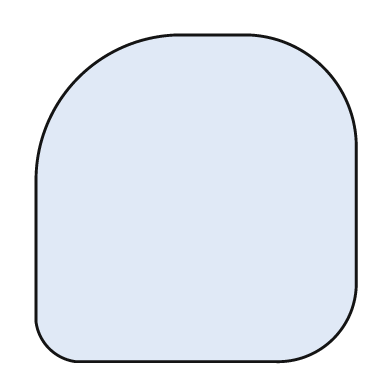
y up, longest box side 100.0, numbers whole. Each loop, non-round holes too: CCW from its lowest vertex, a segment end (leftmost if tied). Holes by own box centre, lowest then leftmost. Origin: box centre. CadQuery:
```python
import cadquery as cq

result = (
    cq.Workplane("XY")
    .moveTo(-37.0, -50.0)
    .lineTo(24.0, -50.0)
    .threePointArc((42.0, -43.0), (49.0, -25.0))
    .lineTo(49.0, 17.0)
    .threePointArc((39.0, 40.0), (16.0, 50.0))
    .lineTo(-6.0, 50.0)
    .threePointArc((-36.0, 37.0), (-49.0, 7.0))
    .lineTo(-49.0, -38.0)
    .threePointArc((-45.0, -46.0), (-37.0, -50.0))
    .close()
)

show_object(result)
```